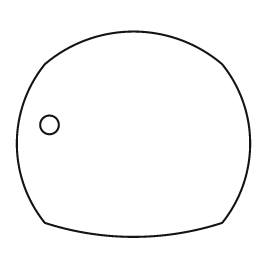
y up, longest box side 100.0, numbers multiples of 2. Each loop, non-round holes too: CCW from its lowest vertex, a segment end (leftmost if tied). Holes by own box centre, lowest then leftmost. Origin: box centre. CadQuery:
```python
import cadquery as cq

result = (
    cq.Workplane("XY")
    .moveTo(-38.0, -38.0)
    .threePointArc((0.0, -44.0), (38.0, -38.0))
    .threePointArc((50.0, -4.0), (38.0, 30.0))
    .threePointArc((0.0, 44.0), (-38.0, 30.0))
    .threePointArc((-50.0, -4.0), (-38.0, -38.0))
    .close()
    .moveTo(-36.0, 4.0)
    .circle(4.0)
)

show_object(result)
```